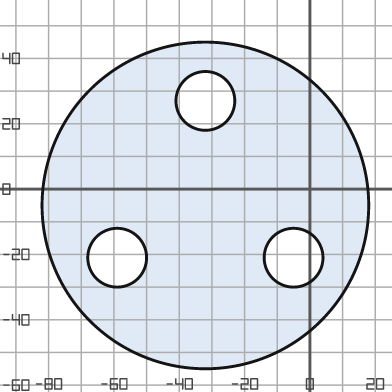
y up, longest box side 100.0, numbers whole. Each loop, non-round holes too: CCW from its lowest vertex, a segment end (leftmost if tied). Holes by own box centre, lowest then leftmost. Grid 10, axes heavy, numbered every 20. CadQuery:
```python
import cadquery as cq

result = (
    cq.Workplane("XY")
    .moveTo(-32.0, -5.0)
    .circle(50.0)
    .moveTo(-59.0, -21.0)
    .circle(9.0)
    .moveTo(-5.0, -21.0)
    .circle(9.0)
    .moveTo(-32.0, 27.0)
    .circle(9.0)
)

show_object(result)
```